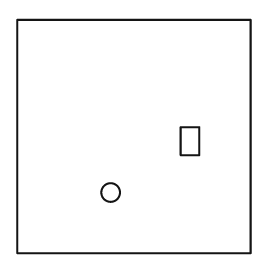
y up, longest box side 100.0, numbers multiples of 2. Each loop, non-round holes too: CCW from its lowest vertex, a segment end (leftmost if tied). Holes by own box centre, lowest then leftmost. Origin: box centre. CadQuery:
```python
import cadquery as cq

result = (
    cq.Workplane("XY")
    .moveTo(-50.0, -50.0)
    .lineTo(50.0, -50.0)
    .lineTo(50.0, 50.0)
    .lineTo(-50.0, 50.0)
    .close()
    .moveTo(-10.0, -24.0)
    .circle(4.0)
    .moveTo(20.0, -8.0)
    .lineTo(28.0, -8.0)
    .lineTo(28.0, 4.0)
    .lineTo(20.0, 4.0)
    .close()
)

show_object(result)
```